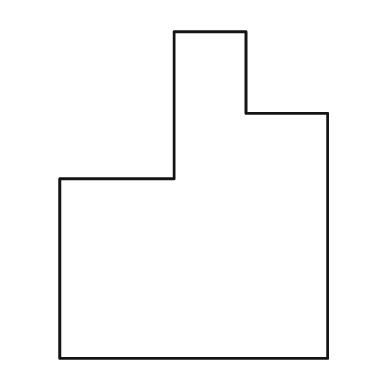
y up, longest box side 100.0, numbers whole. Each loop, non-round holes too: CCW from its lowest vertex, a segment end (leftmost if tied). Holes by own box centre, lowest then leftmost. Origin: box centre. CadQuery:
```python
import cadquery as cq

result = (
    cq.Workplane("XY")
    .moveTo(-41.0, -50.0)
    .lineTo(41.0, -50.0)
    .lineTo(41.0, 25.0)
    .lineTo(16.0, 25.0)
    .lineTo(16.0, 50.0)
    .lineTo(-6.0, 50.0)
    .lineTo(-6.0, 5.0)
    .lineTo(-41.0, 5.0)
    .close()
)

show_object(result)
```